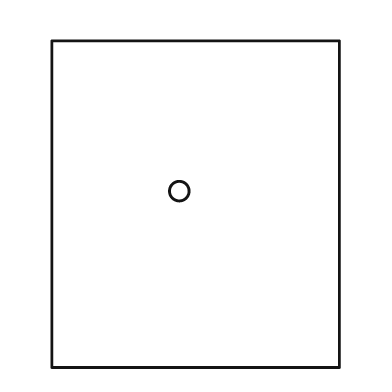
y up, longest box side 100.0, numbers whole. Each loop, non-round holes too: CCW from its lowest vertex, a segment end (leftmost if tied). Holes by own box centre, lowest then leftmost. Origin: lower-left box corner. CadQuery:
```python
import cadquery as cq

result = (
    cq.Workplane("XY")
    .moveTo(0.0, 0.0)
    .lineTo(88.0, 0.0)
    .lineTo(88.0, 100.0)
    .lineTo(0.0, 100.0)
    .close()
    .moveTo(39.0, 54.0)
    .circle(3.0)
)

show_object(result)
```